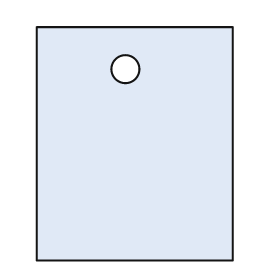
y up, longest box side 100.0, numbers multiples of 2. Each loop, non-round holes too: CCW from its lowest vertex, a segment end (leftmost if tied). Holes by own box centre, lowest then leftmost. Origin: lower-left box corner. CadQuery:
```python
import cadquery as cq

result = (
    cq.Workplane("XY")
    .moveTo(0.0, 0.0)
    .lineTo(84.0, 0.0)
    .lineTo(84.0, 100.0)
    .lineTo(0.0, 100.0)
    .close()
    .moveTo(38.0, 82.0)
    .circle(6.0)
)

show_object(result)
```